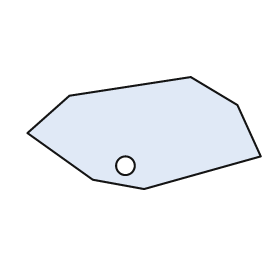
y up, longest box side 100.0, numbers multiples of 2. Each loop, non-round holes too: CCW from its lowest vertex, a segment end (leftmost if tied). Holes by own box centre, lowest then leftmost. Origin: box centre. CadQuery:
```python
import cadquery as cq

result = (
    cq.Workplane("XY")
    .moveTo(0.0, -24.0)
    .lineTo(50.0, -10.0)
    .lineTo(40.0, 12.0)
    .lineTo(20.0, 24.0)
    .lineTo(-32.0, 16.0)
    .lineTo(-50.0, 0.0)
    .lineTo(-22.0, -20.0)
    .close()
    .moveTo(-8.0, -14.0)
    .circle(4.0)
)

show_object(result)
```